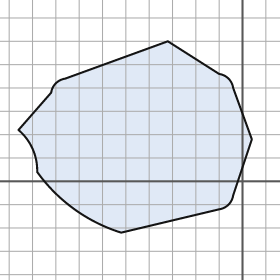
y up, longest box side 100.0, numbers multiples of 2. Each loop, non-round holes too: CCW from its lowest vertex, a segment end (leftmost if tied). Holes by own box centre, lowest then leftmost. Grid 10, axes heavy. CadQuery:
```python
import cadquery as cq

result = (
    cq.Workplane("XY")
    .moveTo(-52.0, -22.0)
    .lineTo(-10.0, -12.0)
    .threePointArc((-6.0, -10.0), (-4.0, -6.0))
    .lineTo(4.0, 18.0)
    .lineTo(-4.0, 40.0)
    .threePointArc((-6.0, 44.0), (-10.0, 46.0))
    .lineTo(-32.0, 60.0)
    .lineTo(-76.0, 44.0)
    .threePointArc((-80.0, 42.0), (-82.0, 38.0))
    .lineTo(-96.0, 22.0)
    .threePointArc((-90.0, 14.0), (-88.0, 4.0))
    .threePointArc((-72.0, -12.0), (-52.0, -22.0))
    .close()
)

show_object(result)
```